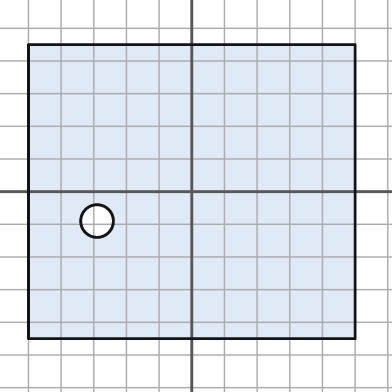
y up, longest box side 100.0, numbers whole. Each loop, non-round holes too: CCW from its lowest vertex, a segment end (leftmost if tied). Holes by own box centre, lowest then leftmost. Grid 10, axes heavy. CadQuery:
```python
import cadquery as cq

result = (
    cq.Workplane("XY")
    .moveTo(-50.0, -45.0)
    .lineTo(50.0, -45.0)
    .lineTo(50.0, 45.0)
    .lineTo(-50.0, 45.0)
    .close()
    .moveTo(-29.0, -9.0)
    .circle(5.0)
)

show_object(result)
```